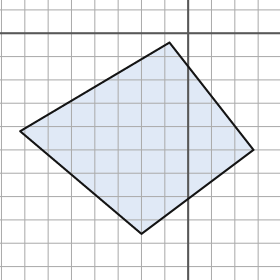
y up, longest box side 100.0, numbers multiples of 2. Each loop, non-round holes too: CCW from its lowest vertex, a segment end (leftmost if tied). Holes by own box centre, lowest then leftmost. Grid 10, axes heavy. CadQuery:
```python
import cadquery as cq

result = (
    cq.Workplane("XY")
    .moveTo(-20.0, -86.0)
    .lineTo(28.0, -50.0)
    .lineTo(-8.0, -4.0)
    .lineTo(-72.0, -42.0)
    .close()
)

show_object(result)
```